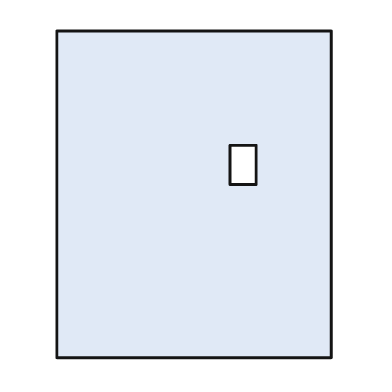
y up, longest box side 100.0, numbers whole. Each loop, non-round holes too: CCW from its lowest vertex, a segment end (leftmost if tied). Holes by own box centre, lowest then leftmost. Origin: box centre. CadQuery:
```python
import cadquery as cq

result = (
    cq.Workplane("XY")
    .moveTo(-42.0, -50.0)
    .lineTo(42.0, -50.0)
    .lineTo(42.0, 50.0)
    .lineTo(-42.0, 50.0)
    .close()
    .moveTo(11.0, 3.0)
    .lineTo(19.0, 3.0)
    .lineTo(19.0, 15.0)
    .lineTo(11.0, 15.0)
    .close()
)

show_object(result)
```